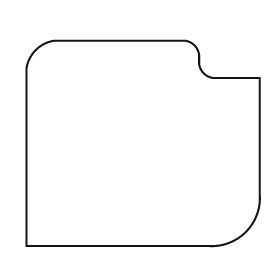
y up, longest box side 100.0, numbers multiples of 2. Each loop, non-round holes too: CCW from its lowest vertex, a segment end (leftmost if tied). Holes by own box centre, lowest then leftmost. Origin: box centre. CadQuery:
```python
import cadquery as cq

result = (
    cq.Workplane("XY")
    .moveTo(-50.0, -44.0)
    .lineTo(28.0, -44.0)
    .threePointArc((44.0, -38.0), (50.0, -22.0))
    .lineTo(50.0, 28.0)
    .lineTo(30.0, 28.0)
    .threePointArc((26.0, 30.0), (24.0, 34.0))
    .lineTo(24.0, 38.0)
    .threePointArc((22.0, 42.0), (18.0, 44.0))
    .lineTo(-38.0, 44.0)
    .threePointArc((-46.0, 40.0), (-50.0, 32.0))
    .close()
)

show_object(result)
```